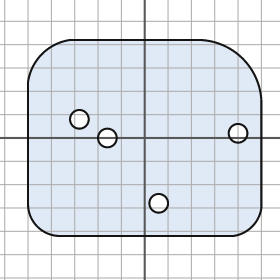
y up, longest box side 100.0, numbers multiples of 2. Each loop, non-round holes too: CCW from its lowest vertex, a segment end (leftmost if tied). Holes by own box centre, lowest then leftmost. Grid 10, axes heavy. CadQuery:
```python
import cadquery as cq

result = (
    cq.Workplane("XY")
    .moveTo(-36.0, -42.0)
    .lineTo(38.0, -42.0)
    .threePointArc((46.0, -38.0), (50.0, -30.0))
    .lineTo(50.0, 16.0)
    .threePointArc((42.0, 34.0), (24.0, 42.0))
    .lineTo(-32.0, 42.0)
    .threePointArc((-44.0, 36.0), (-50.0, 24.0))
    .lineTo(-50.0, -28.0)
    .threePointArc((-46.0, -38.0), (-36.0, -42.0))
    .close()
    .moveTo(6.0, -28.0)
    .circle(4.0)
    .moveTo(-16.0, 0.0)
    .circle(4.0)
    .moveTo(40.0, 2.0)
    .circle(4.0)
    .moveTo(-28.0, 8.0)
    .circle(4.0)
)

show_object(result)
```